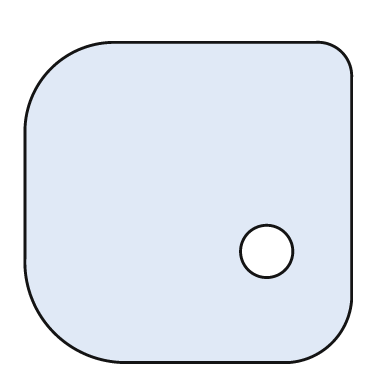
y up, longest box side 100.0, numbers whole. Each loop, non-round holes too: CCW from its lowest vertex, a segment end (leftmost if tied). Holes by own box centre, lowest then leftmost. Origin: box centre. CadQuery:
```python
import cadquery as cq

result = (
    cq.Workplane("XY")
    .moveTo(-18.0, -49.0)
    .lineTo(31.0, -49.0)
    .threePointArc((44.0, -43.0), (50.0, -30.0))
    .lineTo(50.0, 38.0)
    .threePointArc((47.0, 46.0), (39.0, 49.0))
    .lineTo(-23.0, 49.0)
    .threePointArc((-42.0, 41.0), (-50.0, 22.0))
    .lineTo(-50.0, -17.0)
    .threePointArc((-41.0, -40.0), (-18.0, -49.0))
    .close()
    .moveTo(24.0, -15.0)
    .circle(8.0)
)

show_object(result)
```